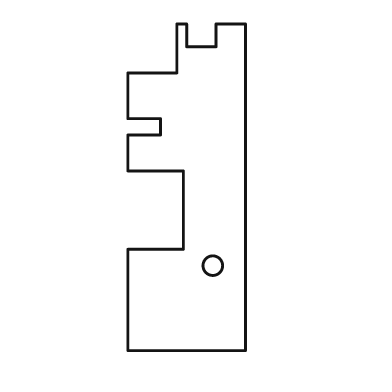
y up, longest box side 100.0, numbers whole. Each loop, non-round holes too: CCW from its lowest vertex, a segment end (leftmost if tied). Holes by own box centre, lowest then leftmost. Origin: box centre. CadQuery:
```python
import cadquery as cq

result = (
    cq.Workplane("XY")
    .moveTo(-18.0, -50.0)
    .lineTo(18.0, -50.0)
    .lineTo(18.0, 50.0)
    .lineTo(9.0, 50.0)
    .lineTo(9.0, 43.0)
    .lineTo(0.0, 43.0)
    .lineTo(0.0, 50.0)
    .lineTo(-3.0, 50.0)
    .lineTo(-3.0, 35.0)
    .lineTo(-18.0, 35.0)
    .lineTo(-18.0, 21.0)
    .lineTo(-8.0, 21.0)
    .lineTo(-8.0, 16.0)
    .lineTo(-18.0, 16.0)
    .lineTo(-18.0, 5.0)
    .lineTo(-1.0, 5.0)
    .lineTo(-1.0, -19.0)
    .lineTo(-18.0, -19.0)
    .close()
    .moveTo(8.0, -24.0)
    .circle(3.0)
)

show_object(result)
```